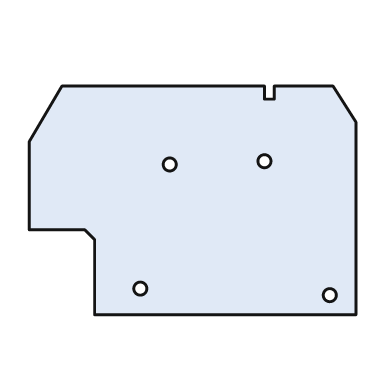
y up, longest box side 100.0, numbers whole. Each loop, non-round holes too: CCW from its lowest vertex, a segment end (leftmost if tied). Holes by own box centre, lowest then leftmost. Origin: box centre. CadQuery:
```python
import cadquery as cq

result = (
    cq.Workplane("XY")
    .moveTo(-30.0, -35.0)
    .lineTo(50.0, -35.0)
    .lineTo(50.0, 24.0)
    .lineTo(43.0, 35.0)
    .lineTo(25.0, 35.0)
    .lineTo(25.0, 31.0)
    .lineTo(22.0, 31.0)
    .lineTo(22.0, 35.0)
    .lineTo(-40.0, 35.0)
    .lineTo(-50.0, 18.0)
    .lineTo(-50.0, -9.0)
    .lineTo(-33.0, -9.0)
    .lineTo(-30.0, -12.0)
    .close()
    .moveTo(42.0, -29.0)
    .circle(2.0)
    .moveTo(-16.0, -27.0)
    .circle(2.0)
    .moveTo(-7.0, 11.0)
    .circle(2.0)
    .moveTo(22.0, 12.0)
    .circle(2.0)
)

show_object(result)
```